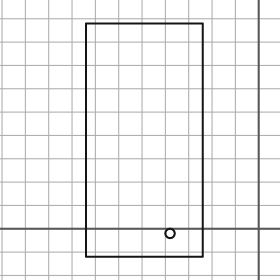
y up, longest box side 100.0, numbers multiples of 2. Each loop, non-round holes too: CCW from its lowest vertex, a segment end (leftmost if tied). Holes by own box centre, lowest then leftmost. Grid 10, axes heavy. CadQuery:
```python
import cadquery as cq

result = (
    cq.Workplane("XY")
    .moveTo(-74.0, -12.0)
    .lineTo(-24.0, -12.0)
    .lineTo(-24.0, 88.0)
    .lineTo(-74.0, 88.0)
    .close()
    .moveTo(-38.0, -2.0)
    .circle(2.0)
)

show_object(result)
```